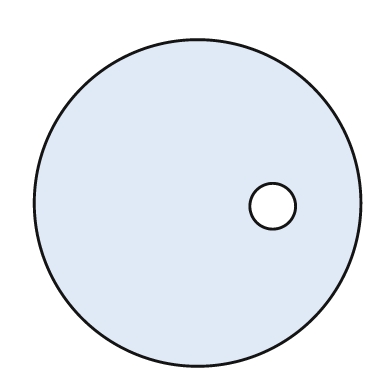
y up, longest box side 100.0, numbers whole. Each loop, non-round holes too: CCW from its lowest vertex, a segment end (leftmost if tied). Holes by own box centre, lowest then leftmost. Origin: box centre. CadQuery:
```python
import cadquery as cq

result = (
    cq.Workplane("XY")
    .moveTo(0.0, 0.0)
    .circle(50.0)
    .moveTo(23.0, -1.0)
    .circle(7.0)
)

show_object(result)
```